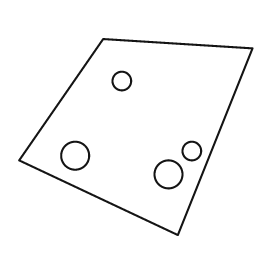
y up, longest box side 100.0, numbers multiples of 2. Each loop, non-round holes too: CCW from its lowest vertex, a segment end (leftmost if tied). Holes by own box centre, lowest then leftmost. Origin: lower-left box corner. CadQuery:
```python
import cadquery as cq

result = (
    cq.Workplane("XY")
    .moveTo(68.0, 0.0)
    .lineTo(100.0, 80.0)
    .lineTo(36.0, 84.0)
    .lineTo(0.0, 32.0)
    .close()
    .moveTo(64.0, 26.0)
    .circle(6.0)
    .moveTo(24.0, 34.0)
    .circle(6.0)
    .moveTo(74.0, 36.0)
    .circle(4.0)
    .moveTo(44.0, 66.0)
    .circle(4.0)
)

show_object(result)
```